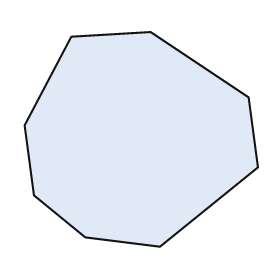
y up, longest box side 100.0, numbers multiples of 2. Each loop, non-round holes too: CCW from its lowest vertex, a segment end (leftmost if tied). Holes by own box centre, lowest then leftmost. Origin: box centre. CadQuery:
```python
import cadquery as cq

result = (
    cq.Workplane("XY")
    .moveTo(8.0, -46.0)
    .lineTo(50.0, -12.0)
    .lineTo(46.0, 18.0)
    .lineTo(4.0, 46.0)
    .lineTo(-30.0, 44.0)
    .lineTo(-50.0, 6.0)
    .lineTo(-46.0, -24.0)
    .lineTo(-24.0, -42.0)
    .close()
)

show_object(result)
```